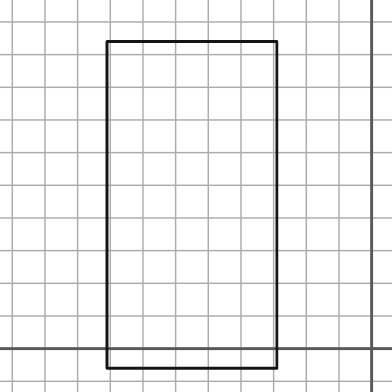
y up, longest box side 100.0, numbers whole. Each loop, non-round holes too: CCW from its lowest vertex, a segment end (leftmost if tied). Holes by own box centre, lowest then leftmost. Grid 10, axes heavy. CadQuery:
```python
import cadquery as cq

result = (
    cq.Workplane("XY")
    .moveTo(-81.0, -6.0)
    .lineTo(-29.0, -6.0)
    .lineTo(-29.0, 94.0)
    .lineTo(-81.0, 94.0)
    .close()
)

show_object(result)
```